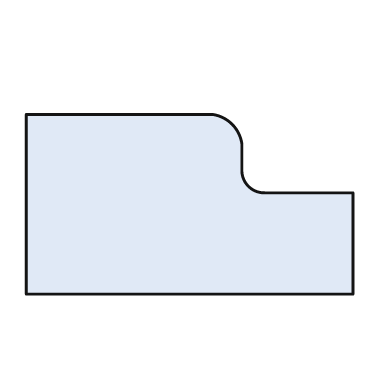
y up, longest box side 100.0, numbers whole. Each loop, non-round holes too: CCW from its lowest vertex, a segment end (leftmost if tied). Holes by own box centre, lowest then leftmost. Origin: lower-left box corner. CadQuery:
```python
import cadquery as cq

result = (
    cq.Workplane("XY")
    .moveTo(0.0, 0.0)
    .lineTo(100.0, 0.0)
    .lineTo(100.0, 31.0)
    .lineTo(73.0, 31.0)
    .threePointArc((68.0, 33.0), (66.0, 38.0))
    .lineTo(66.0, 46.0)
    .threePointArc((63.0, 52.0), (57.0, 55.0))
    .lineTo(0.0, 55.0)
    .close()
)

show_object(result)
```